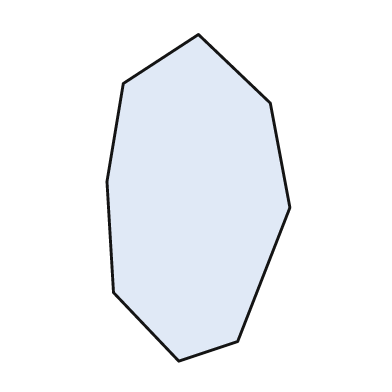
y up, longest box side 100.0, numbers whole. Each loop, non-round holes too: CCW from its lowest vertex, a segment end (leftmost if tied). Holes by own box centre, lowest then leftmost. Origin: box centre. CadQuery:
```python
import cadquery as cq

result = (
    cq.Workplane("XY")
    .moveTo(-6.0, -50.0)
    .lineTo(12.0, -44.0)
    .lineTo(28.0, -3.0)
    .lineTo(22.0, 29.0)
    .lineTo(0.0, 50.0)
    .lineTo(-23.0, 35.0)
    .lineTo(-28.0, 5.0)
    .lineTo(-26.0, -29.0)
    .close()
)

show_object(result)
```